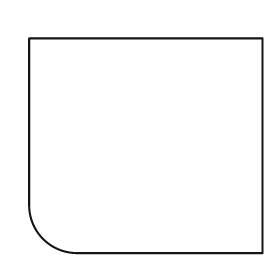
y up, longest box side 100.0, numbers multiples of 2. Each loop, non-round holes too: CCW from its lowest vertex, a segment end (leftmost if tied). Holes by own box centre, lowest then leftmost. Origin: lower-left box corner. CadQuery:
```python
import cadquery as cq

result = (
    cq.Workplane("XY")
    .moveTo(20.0, 0.0)
    .lineTo(100.0, 0.0)
    .lineTo(100.0, 92.0)
    .lineTo(0.0, 92.0)
    .lineTo(0.0, 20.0)
    .threePointArc((6.0, 6.0), (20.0, 0.0))
    .close()
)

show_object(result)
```